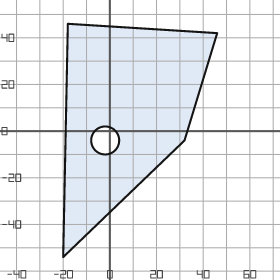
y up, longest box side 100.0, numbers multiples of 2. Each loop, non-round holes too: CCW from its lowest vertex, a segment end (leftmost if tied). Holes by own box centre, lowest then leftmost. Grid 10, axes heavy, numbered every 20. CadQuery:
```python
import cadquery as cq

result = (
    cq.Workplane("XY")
    .moveTo(-20.0, -54.0)
    .lineTo(32.0, -4.0)
    .lineTo(46.0, 42.0)
    .lineTo(-18.0, 46.0)
    .close()
    .moveTo(-2.0, -4.0)
    .circle(6.0)
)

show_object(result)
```